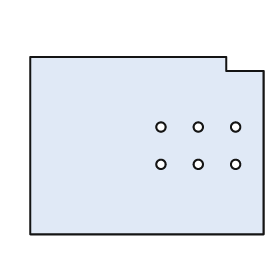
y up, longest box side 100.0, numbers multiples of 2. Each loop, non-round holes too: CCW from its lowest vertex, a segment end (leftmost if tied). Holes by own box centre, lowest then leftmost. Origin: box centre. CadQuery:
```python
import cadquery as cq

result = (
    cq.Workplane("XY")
    .moveTo(-50.0, -38.0)
    .lineTo(50.0, -38.0)
    .lineTo(50.0, 32.0)
    .lineTo(34.0, 32.0)
    .lineTo(34.0, 38.0)
    .lineTo(-50.0, 38.0)
    .close()
    .moveTo(6.0, -8.0)
    .circle(2.0)
    .moveTo(22.0, -8.0)
    .circle(2.0)
    .moveTo(38.0, -8.0)
    .circle(2.0)
    .moveTo(6.0, 8.0)
    .circle(2.0)
    .moveTo(22.0, 8.0)
    .circle(2.0)
    .moveTo(38.0, 8.0)
    .circle(2.0)
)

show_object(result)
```